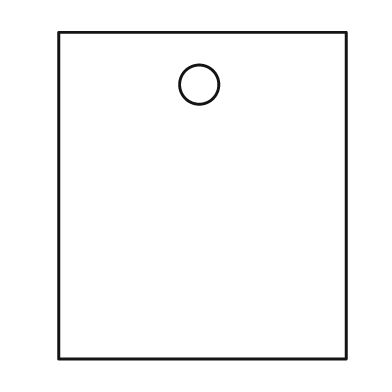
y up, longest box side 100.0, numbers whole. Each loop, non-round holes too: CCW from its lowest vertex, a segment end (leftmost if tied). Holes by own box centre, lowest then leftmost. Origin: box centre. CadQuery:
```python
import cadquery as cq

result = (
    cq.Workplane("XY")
    .moveTo(-44.0, -50.0)
    .lineTo(44.0, -50.0)
    .lineTo(44.0, 50.0)
    .lineTo(-44.0, 50.0)
    .close()
    .moveTo(-1.0, 34.0)
    .circle(6.0)
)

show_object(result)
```